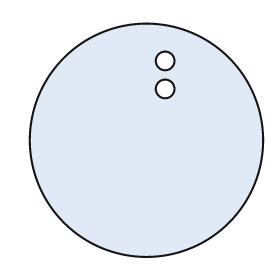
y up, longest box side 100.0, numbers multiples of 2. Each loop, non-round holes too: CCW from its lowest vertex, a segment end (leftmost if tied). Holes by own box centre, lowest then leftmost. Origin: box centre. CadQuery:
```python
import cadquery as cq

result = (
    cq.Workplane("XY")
    .moveTo(0.0, 0.0)
    .circle(50.0)
    .moveTo(8.0, 22.0)
    .circle(4.0)
    .moveTo(8.0, 34.0)
    .circle(4.0)
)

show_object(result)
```